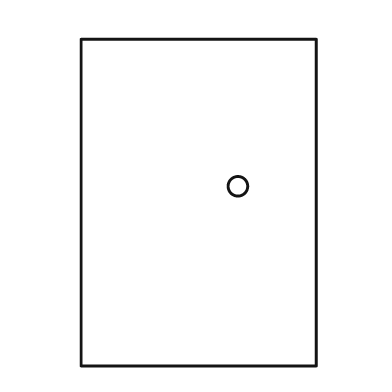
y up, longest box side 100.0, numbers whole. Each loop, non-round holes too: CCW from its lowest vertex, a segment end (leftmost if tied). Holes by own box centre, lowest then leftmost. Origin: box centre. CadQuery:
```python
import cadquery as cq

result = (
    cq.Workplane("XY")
    .moveTo(-36.0, -50.0)
    .lineTo(36.0, -50.0)
    .lineTo(36.0, 50.0)
    .lineTo(-36.0, 50.0)
    .close()
    .moveTo(12.0, 5.0)
    .circle(3.0)
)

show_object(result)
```